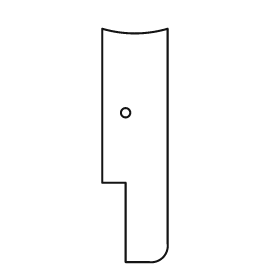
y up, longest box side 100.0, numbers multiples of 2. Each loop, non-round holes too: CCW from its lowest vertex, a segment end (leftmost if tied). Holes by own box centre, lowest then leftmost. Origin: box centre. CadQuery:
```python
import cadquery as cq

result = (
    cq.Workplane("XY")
    .moveTo(-4.0, -50.0)
    .lineTo(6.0, -50.0)
    .threePointArc((12.0, -48.0), (14.0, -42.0))
    .lineTo(14.0, 50.0)
    .threePointArc((0.0, 48.0), (-14.0, 50.0))
    .lineTo(-14.0, -16.0)
    .lineTo(-4.0, -16.0)
    .close()
    .moveTo(-4.0, 14.0)
    .circle(2.0)
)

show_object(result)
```